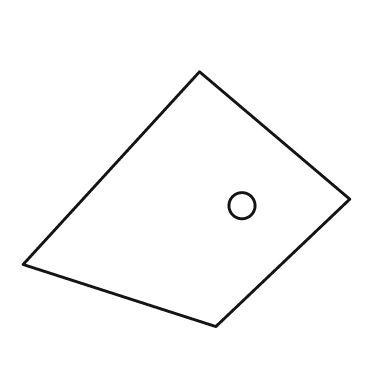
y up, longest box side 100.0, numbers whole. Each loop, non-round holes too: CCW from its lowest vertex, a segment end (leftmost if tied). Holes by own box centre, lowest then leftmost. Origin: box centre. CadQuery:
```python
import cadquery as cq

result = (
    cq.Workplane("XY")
    .moveTo(9.0, -39.0)
    .lineTo(50.0, 0.0)
    .lineTo(4.0, 39.0)
    .lineTo(-50.0, -20.0)
    .close()
    .moveTo(17.0, -2.0)
    .circle(4.0)
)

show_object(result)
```